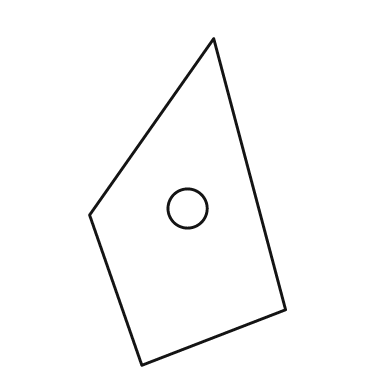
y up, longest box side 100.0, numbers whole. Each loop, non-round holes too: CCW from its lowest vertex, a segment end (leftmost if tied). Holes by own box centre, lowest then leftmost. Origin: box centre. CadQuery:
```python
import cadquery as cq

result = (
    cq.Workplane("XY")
    .moveTo(-14.0, -50.0)
    .lineTo(30.0, -33.0)
    .lineTo(8.0, 50.0)
    .lineTo(-30.0, -4.0)
    .close()
    .moveTo(0.0, -2.0)
    .circle(6.0)
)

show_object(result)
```